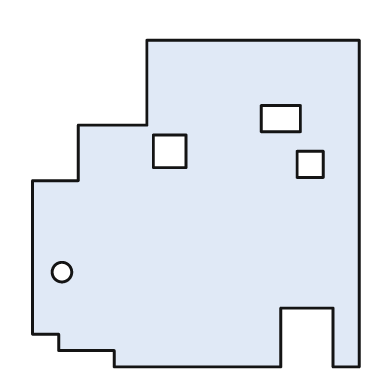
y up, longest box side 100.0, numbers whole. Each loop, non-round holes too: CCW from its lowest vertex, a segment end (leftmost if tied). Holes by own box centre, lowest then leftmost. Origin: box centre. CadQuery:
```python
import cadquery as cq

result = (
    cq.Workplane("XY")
    .moveTo(-25.0, -50.0)
    .lineTo(26.0, -50.0)
    .lineTo(26.0, -32.0)
    .lineTo(42.0, -32.0)
    .lineTo(42.0, -50.0)
    .lineTo(50.0, -50.0)
    .lineTo(50.0, 50.0)
    .lineTo(-15.0, 50.0)
    .lineTo(-15.0, 24.0)
    .lineTo(-36.0, 24.0)
    .lineTo(-36.0, 7.0)
    .lineTo(-50.0, 7.0)
    .lineTo(-50.0, -40.0)
    .lineTo(-42.0, -40.0)
    .lineTo(-42.0, -45.0)
    .lineTo(-25.0, -45.0)
    .close()
    .moveTo(-41.0, -21.0)
    .circle(3.0)
    .moveTo(31.0, 8.0)
    .lineTo(39.0, 8.0)
    .lineTo(39.0, 16.0)
    .lineTo(31.0, 16.0)
    .close()
    .moveTo(-13.0, 11.0)
    .lineTo(-3.0, 11.0)
    .lineTo(-3.0, 21.0)
    .lineTo(-13.0, 21.0)
    .close()
    .moveTo(20.0, 22.0)
    .lineTo(32.0, 22.0)
    .lineTo(32.0, 30.0)
    .lineTo(20.0, 30.0)
    .close()
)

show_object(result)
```